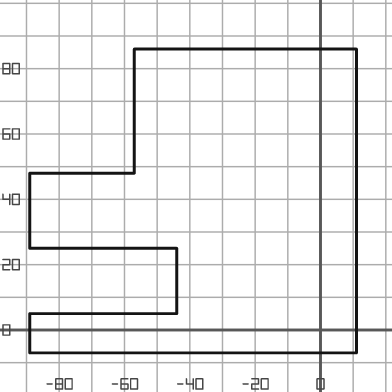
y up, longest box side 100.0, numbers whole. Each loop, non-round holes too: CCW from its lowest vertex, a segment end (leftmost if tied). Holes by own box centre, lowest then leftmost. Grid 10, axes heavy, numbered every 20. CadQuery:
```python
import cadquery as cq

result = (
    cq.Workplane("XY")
    .moveTo(-89.0, -7.0)
    .lineTo(11.0, -7.0)
    .lineTo(11.0, 86.0)
    .lineTo(-57.0, 86.0)
    .lineTo(-57.0, 48.0)
    .lineTo(-89.0, 48.0)
    .lineTo(-89.0, 25.0)
    .lineTo(-44.0, 25.0)
    .lineTo(-44.0, 5.0)
    .lineTo(-89.0, 5.0)
    .close()
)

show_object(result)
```